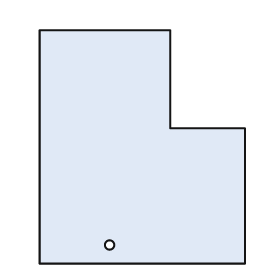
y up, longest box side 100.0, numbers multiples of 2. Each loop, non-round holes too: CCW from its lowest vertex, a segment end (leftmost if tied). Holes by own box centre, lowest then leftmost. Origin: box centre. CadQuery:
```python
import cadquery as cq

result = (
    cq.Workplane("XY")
    .moveTo(-44.0, -50.0)
    .lineTo(44.0, -50.0)
    .lineTo(44.0, 8.0)
    .lineTo(12.0, 8.0)
    .lineTo(12.0, 50.0)
    .lineTo(-44.0, 50.0)
    .close()
    .moveTo(-14.0, -42.0)
    .circle(2.0)
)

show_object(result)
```